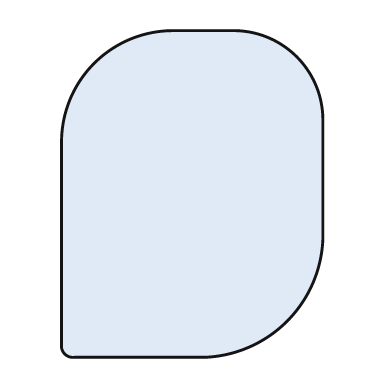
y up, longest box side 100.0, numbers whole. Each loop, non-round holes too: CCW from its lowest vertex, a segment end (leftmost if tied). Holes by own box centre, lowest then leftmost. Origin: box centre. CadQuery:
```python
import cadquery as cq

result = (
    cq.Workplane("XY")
    .moveTo(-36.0, -50.0)
    .lineTo(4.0, -50.0)
    .threePointArc((29.0, -39.0), (40.0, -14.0))
    .lineTo(40.0, 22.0)
    .threePointArc((32.0, 42.0), (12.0, 50.0))
    .lineTo(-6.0, 50.0)
    .threePointArc((-30.0, 40.0), (-40.0, 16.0))
    .lineTo(-40.0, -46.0)
    .threePointArc((-39.0, -49.0), (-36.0, -50.0))
    .close()
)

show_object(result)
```